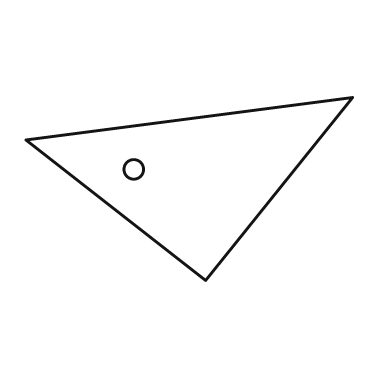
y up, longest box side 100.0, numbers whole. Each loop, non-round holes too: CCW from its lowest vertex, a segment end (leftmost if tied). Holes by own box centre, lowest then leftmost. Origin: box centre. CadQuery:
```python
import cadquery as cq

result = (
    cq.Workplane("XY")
    .moveTo(5.0, -28.0)
    .lineTo(50.0, 28.0)
    .lineTo(-50.0, 15.0)
    .close()
    .moveTo(-17.0, 6.0)
    .circle(3.0)
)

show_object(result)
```